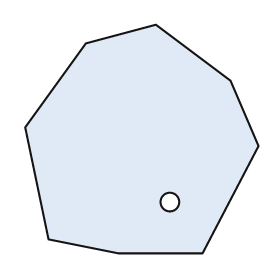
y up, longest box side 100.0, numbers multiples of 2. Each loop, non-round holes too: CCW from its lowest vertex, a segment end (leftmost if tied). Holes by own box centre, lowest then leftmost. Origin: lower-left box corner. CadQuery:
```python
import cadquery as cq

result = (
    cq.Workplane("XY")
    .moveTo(40.0, 0.0)
    .lineTo(76.0, 0.0)
    .lineTo(100.0, 46.0)
    .lineTo(88.0, 74.0)
    .lineTo(56.0, 98.0)
    .lineTo(26.0, 90.0)
    .lineTo(0.0, 54.0)
    .lineTo(10.0, 6.0)
    .close()
    .moveTo(62.0, 22.0)
    .circle(4.0)
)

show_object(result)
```